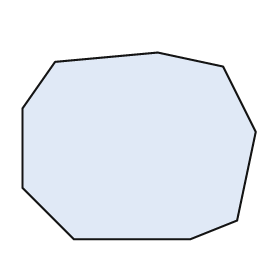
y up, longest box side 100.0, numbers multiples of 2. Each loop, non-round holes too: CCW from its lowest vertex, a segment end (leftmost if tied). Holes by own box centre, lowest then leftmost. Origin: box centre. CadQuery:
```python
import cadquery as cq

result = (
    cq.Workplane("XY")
    .moveTo(-28.0, -40.0)
    .lineTo(22.0, -40.0)
    .lineTo(42.0, -32.0)
    .lineTo(50.0, 6.0)
    .lineTo(36.0, 34.0)
    .lineTo(8.0, 40.0)
    .lineTo(-36.0, 36.0)
    .lineTo(-50.0, 16.0)
    .lineTo(-50.0, -18.0)
    .close()
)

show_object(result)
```